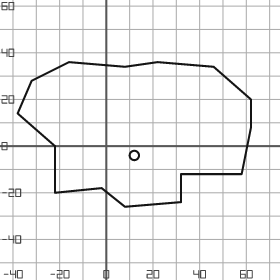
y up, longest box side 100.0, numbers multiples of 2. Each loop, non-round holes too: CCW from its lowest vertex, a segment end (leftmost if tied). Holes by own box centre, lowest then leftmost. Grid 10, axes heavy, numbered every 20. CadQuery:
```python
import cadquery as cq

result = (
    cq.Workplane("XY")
    .moveTo(8.0, -26.0)
    .lineTo(32.0, -24.0)
    .lineTo(32.0, -12.0)
    .lineTo(58.0, -12.0)
    .lineTo(62.0, 8.0)
    .lineTo(62.0, 20.0)
    .lineTo(46.0, 34.0)
    .lineTo(22.0, 36.0)
    .lineTo(8.0, 34.0)
    .lineTo(-16.0, 36.0)
    .lineTo(-32.0, 28.0)
    .lineTo(-38.0, 14.0)
    .lineTo(-22.0, 0.0)
    .lineTo(-22.0, -20.0)
    .lineTo(-2.0, -18.0)
    .close()
    .moveTo(12.0, -4.0)
    .circle(2.0)
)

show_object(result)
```